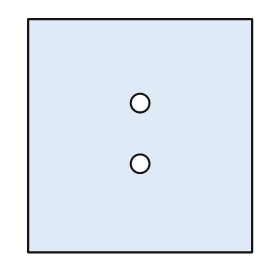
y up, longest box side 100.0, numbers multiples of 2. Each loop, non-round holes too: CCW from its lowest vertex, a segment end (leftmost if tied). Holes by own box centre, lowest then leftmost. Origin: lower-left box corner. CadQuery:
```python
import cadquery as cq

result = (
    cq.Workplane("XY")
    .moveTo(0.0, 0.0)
    .lineTo(96.0, 0.0)
    .lineTo(96.0, 100.0)
    .lineTo(0.0, 100.0)
    .close()
    .moveTo(48.0, 38.0)
    .circle(4.0)
    .moveTo(48.0, 64.0)
    .circle(4.0)
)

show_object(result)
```